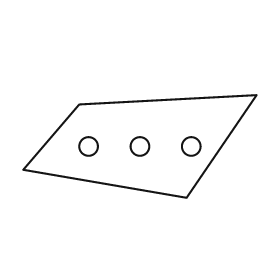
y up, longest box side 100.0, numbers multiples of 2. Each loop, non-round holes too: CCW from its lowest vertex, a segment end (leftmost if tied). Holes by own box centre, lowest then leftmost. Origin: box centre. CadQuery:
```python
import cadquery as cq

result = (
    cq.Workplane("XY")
    .moveTo(20.0, -22.0)
    .lineTo(50.0, 22.0)
    .lineTo(-26.0, 18.0)
    .lineTo(-50.0, -10.0)
    .close()
    .moveTo(-22.0, 0.0)
    .circle(4.0)
    .moveTo(0.0, 0.0)
    .circle(4.0)
    .moveTo(22.0, 0.0)
    .circle(4.0)
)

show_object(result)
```